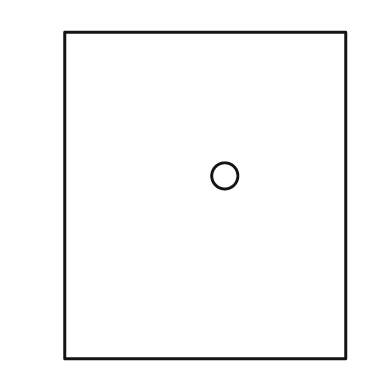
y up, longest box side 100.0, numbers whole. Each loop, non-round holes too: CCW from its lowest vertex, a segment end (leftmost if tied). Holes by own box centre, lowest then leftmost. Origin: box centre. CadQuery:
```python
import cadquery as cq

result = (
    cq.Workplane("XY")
    .moveTo(-43.0, -50.0)
    .lineTo(43.0, -50.0)
    .lineTo(43.0, 50.0)
    .lineTo(-43.0, 50.0)
    .close()
    .moveTo(6.0, 6.0)
    .circle(4.0)
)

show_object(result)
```